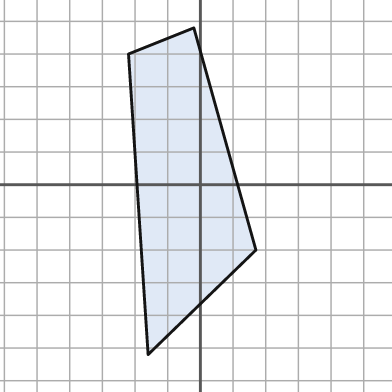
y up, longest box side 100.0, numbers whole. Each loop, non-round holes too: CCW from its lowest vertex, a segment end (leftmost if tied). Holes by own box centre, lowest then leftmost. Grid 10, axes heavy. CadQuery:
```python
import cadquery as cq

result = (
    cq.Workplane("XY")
    .moveTo(-16.0, -52.0)
    .lineTo(17.0, -20.0)
    .lineTo(-2.0, 48.0)
    .lineTo(-22.0, 40.0)
    .close()
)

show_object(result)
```